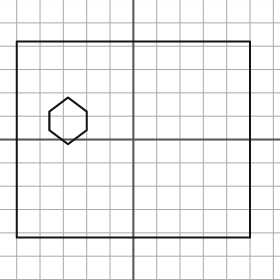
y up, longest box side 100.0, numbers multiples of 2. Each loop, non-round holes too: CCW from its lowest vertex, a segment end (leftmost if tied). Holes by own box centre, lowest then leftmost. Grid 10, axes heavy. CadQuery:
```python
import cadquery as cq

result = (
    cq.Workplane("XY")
    .moveTo(-50.0, -42.0)
    .lineTo(50.0, -42.0)
    .lineTo(50.0, 42.0)
    .lineTo(-50.0, 42.0)
    .close()
    .moveTo(-28.0, -2.0)
    .lineTo(-20.0, 4.0)
    .lineTo(-20.0, 12.0)
    .lineTo(-28.0, 18.0)
    .lineTo(-36.0, 12.0)
    .lineTo(-36.0, 4.0)
    .close()
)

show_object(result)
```